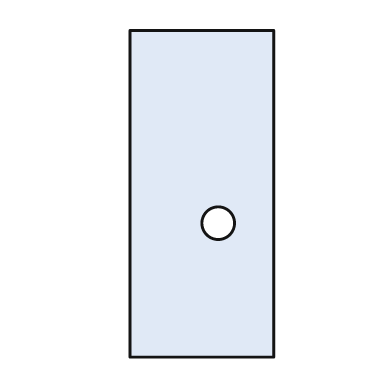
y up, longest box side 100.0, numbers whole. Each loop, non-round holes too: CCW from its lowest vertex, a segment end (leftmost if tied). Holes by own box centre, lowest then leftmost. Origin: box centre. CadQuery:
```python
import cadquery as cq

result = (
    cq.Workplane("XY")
    .moveTo(-22.0, -50.0)
    .lineTo(22.0, -50.0)
    .lineTo(22.0, 50.0)
    .lineTo(-22.0, 50.0)
    .close()
    .moveTo(5.0, -9.0)
    .circle(5.0)
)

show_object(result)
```